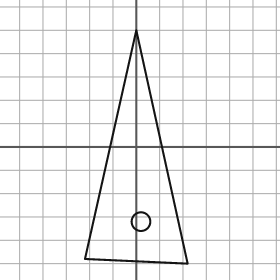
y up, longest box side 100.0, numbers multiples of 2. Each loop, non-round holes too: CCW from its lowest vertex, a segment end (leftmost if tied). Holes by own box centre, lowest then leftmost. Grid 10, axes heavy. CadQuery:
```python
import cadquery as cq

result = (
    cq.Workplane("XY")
    .moveTo(22.0, -50.0)
    .lineTo(0.0, 50.0)
    .lineTo(-22.0, -48.0)
    .close()
    .moveTo(2.0, -32.0)
    .circle(4.0)
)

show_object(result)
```